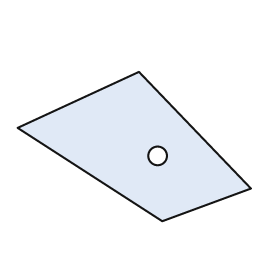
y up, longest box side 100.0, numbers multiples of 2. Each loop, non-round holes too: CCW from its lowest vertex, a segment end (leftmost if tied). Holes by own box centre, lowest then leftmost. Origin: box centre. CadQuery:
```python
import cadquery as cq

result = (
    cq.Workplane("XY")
    .moveTo(12.0, -32.0)
    .lineTo(50.0, -18.0)
    .lineTo(2.0, 32.0)
    .lineTo(-50.0, 8.0)
    .close()
    .moveTo(10.0, -4.0)
    .circle(4.0)
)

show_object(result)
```